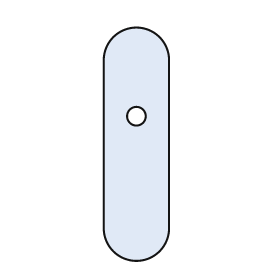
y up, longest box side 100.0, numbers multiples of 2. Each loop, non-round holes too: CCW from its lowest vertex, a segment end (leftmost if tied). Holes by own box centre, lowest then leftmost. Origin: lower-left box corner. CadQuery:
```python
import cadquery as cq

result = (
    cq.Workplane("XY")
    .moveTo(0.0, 14.0)
    .threePointArc((14.0, 0.0), (28.0, 14.0))
    .lineTo(28.0, 86.0)
    .threePointArc((14.0, 100.0), (0.0, 86.0))
    .close()
    .moveTo(14.0, 62.0)
    .circle(4.0)
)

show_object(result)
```